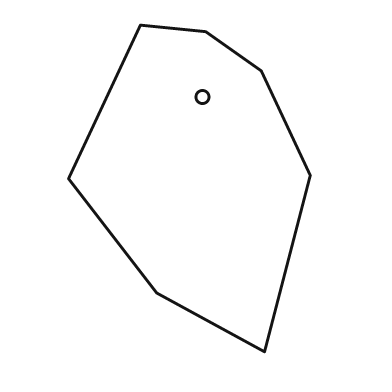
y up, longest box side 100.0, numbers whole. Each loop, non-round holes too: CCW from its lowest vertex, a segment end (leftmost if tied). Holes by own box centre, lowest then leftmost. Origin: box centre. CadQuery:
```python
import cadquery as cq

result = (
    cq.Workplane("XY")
    .moveTo(23.0, -50.0)
    .lineTo(37.0, 4.0)
    .lineTo(22.0, 36.0)
    .lineTo(5.0, 48.0)
    .lineTo(-15.0, 50.0)
    .lineTo(-37.0, 3.0)
    .lineTo(-10.0, -32.0)
    .close()
    .moveTo(4.0, 28.0)
    .circle(2.0)
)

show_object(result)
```